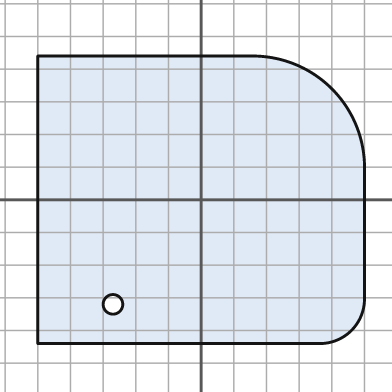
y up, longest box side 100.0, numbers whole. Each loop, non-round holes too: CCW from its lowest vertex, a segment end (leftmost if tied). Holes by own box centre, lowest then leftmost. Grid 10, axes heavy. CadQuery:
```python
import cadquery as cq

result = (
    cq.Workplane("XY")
    .moveTo(-50.0, -44.0)
    .lineTo(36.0, -44.0)
    .threePointArc((46.0, -40.0), (50.0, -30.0))
    .lineTo(50.0, 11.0)
    .threePointArc((40.0, 34.0), (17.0, 44.0))
    .lineTo(-50.0, 44.0)
    .close()
    .moveTo(-27.0, -32.0)
    .circle(3.0)
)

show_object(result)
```